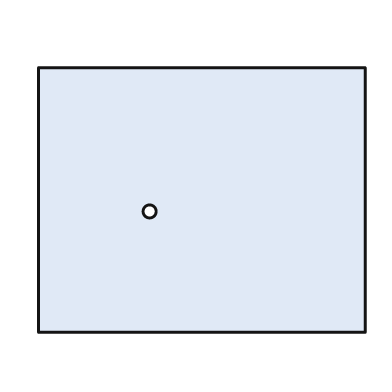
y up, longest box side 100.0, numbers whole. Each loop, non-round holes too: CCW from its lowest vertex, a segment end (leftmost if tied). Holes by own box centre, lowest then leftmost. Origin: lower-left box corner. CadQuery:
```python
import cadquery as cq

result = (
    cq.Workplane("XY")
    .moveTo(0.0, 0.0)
    .lineTo(100.0, 0.0)
    .lineTo(100.0, 81.0)
    .lineTo(0.0, 81.0)
    .close()
    .moveTo(34.0, 37.0)
    .circle(2.0)
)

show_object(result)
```